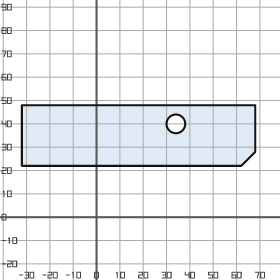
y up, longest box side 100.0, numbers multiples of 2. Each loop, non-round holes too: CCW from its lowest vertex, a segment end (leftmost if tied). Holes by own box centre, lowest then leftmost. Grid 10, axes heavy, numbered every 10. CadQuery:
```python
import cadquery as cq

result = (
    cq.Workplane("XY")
    .moveTo(-32.0, 22.0)
    .lineTo(62.0, 22.0)
    .lineTo(68.0, 28.0)
    .lineTo(68.0, 48.0)
    .lineTo(-32.0, 48.0)
    .close()
    .moveTo(34.0, 40.0)
    .circle(4.0)
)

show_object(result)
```